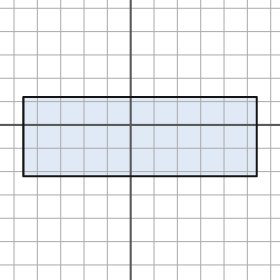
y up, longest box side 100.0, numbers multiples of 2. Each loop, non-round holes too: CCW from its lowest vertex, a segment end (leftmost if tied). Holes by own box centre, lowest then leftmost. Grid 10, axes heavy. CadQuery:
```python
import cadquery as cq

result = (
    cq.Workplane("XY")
    .moveTo(-46.0, -22.0)
    .lineTo(54.0, -22.0)
    .lineTo(54.0, 12.0)
    .lineTo(-46.0, 12.0)
    .close()
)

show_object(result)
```